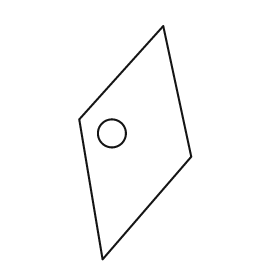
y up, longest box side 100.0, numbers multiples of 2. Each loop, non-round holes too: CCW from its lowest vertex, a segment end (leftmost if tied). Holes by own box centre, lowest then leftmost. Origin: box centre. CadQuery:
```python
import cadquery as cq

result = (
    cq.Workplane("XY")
    .moveTo(-14.0, -50.0)
    .lineTo(24.0, -6.0)
    .lineTo(12.0, 50.0)
    .lineTo(-24.0, 10.0)
    .close()
    .moveTo(-10.0, 4.0)
    .circle(6.0)
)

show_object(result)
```